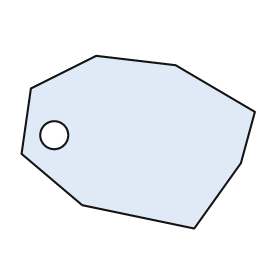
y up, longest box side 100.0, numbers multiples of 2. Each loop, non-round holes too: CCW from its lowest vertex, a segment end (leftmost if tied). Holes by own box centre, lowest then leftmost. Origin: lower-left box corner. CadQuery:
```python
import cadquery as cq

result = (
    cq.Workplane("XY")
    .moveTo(74.0, 0.0)
    .lineTo(94.0, 28.0)
    .lineTo(100.0, 50.0)
    .lineTo(66.0, 70.0)
    .lineTo(32.0, 74.0)
    .lineTo(4.0, 60.0)
    .lineTo(0.0, 32.0)
    .lineTo(26.0, 10.0)
    .close()
    .moveTo(14.0, 40.0)
    .circle(6.0)
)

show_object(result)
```